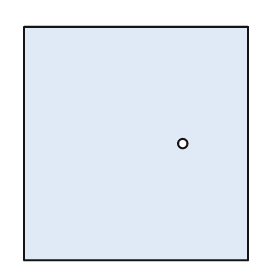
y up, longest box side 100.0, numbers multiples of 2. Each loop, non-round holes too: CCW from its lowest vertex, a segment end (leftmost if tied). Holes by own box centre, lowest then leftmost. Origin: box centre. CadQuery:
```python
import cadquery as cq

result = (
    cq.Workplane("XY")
    .moveTo(-48.0, -50.0)
    .lineTo(48.0, -50.0)
    .lineTo(48.0, 50.0)
    .lineTo(-48.0, 50.0)
    .close()
    .moveTo(20.0, 0.0)
    .circle(2.0)
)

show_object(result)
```